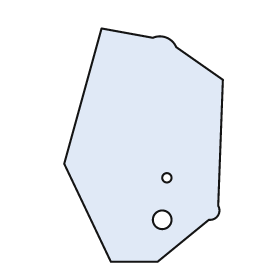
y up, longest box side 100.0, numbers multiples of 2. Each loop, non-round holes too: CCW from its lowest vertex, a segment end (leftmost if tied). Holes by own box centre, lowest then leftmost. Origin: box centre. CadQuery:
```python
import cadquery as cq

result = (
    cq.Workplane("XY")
    .moveTo(-14.0, -50.0)
    .lineTo(6.0, -50.0)
    .lineTo(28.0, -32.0)
    .threePointArc((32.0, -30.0), (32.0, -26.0))
    .lineTo(34.0, 28.0)
    .lineTo(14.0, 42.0)
    .threePointArc((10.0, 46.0), (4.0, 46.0))
    .lineTo(-18.0, 50.0)
    .lineTo(-34.0, -8.0)
    .close()
    .moveTo(8.0, -32.0)
    .circle(4.0)
    .moveTo(10.0, -14.0)
    .circle(2.0)
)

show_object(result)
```